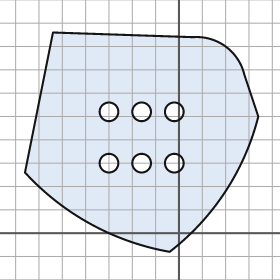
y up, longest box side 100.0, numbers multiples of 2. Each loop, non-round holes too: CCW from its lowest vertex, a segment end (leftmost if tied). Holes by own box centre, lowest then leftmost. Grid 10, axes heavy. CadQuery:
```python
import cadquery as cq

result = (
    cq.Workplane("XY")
    .moveTo(-4.0, -8.0)
    .threePointArc((20.0, 18.0), (34.0, 50.0))
    .lineTo(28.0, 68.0)
    .threePointArc((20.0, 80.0), (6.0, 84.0))
    .lineTo(-54.0, 86.0)
    .lineTo(-66.0, 26.0)
    .threePointArc((-38.0, 4.0), (-4.0, -8.0))
    .close()
    .moveTo(-30.0, 30.0)
    .circle(4.0)
    .moveTo(-16.0, 30.0)
    .circle(4.0)
    .moveTo(-2.0, 30.0)
    .circle(4.0)
    .moveTo(-30.0, 52.0)
    .circle(4.0)
    .moveTo(-16.0, 52.0)
    .circle(4.0)
    .moveTo(-2.0, 52.0)
    .circle(4.0)
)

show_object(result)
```